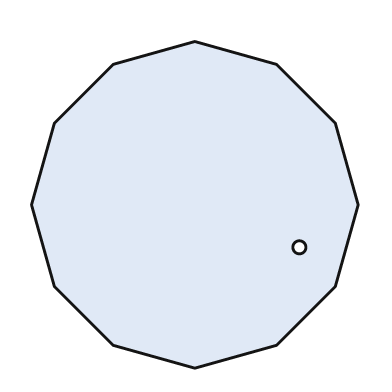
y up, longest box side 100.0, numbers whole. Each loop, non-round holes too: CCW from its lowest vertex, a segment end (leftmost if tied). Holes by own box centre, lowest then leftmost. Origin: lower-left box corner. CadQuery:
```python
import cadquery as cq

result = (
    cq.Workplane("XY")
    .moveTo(50.0, 0.0)
    .lineTo(75.0, 7.0)
    .lineTo(93.0, 25.0)
    .lineTo(100.0, 50.0)
    .lineTo(93.0, 75.0)
    .lineTo(75.0, 93.0)
    .lineTo(50.0, 100.0)
    .lineTo(25.0, 93.0)
    .lineTo(7.0, 75.0)
    .lineTo(0.0, 50.0)
    .lineTo(7.0, 25.0)
    .lineTo(25.0, 7.0)
    .close()
    .moveTo(82.0, 37.0)
    .circle(2.0)
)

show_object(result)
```